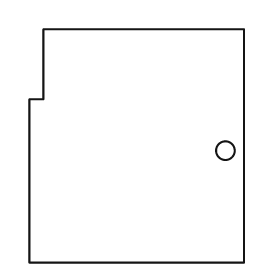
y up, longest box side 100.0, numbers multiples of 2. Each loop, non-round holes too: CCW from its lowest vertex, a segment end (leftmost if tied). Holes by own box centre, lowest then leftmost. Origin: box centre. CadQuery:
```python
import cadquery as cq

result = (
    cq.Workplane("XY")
    .moveTo(-46.0, -50.0)
    .lineTo(46.0, -50.0)
    .lineTo(46.0, 50.0)
    .lineTo(-40.0, 50.0)
    .lineTo(-40.0, 20.0)
    .lineTo(-46.0, 20.0)
    .close()
    .moveTo(38.0, -2.0)
    .circle(4.0)
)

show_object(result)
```